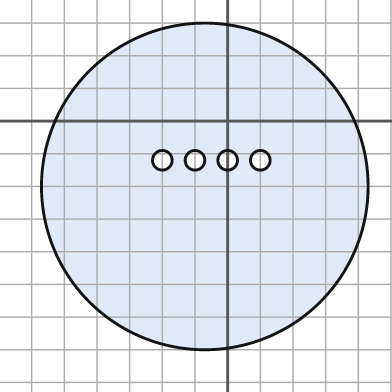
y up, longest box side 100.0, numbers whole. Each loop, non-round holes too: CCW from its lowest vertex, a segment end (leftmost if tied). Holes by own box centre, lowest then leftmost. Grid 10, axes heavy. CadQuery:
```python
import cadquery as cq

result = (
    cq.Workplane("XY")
    .moveTo(-7.0, -20.0)
    .circle(50.0)
    .moveTo(-20.0, -12.0)
    .circle(3.0)
    .moveTo(-10.0, -12.0)
    .circle(3.0)
    .moveTo(0.0, -12.0)
    .circle(3.0)
    .moveTo(10.0, -12.0)
    .circle(3.0)
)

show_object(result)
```